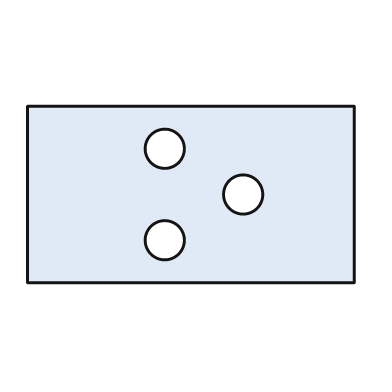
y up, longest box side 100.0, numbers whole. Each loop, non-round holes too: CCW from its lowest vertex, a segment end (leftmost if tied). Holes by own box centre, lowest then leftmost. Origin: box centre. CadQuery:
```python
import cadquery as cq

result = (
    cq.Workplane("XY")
    .moveTo(-50.0, -27.0)
    .lineTo(50.0, -27.0)
    .lineTo(50.0, 27.0)
    .lineTo(-50.0, 27.0)
    .close()
    .moveTo(-8.0, -14.0)
    .circle(6.0)
    .moveTo(16.0, 0.0)
    .circle(6.0)
    .moveTo(-8.0, 14.0)
    .circle(6.0)
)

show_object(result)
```